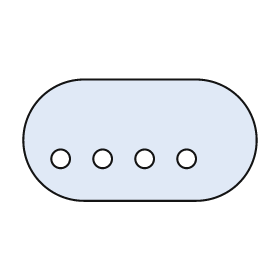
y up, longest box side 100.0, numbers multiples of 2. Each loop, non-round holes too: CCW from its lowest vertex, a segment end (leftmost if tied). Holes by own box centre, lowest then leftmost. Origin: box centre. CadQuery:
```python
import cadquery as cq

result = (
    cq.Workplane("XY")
    .moveTo(-24.0, -26.0)
    .lineTo(24.0, -26.0)
    .threePointArc((50.0, 0.0), (24.0, 26.0))
    .lineTo(-24.0, 26.0)
    .threePointArc((-50.0, 0.0), (-24.0, -26.0))
    .close()
    .moveTo(-34.0, -8.0)
    .circle(4.0)
    .moveTo(-16.0, -8.0)
    .circle(4.0)
    .moveTo(2.0, -8.0)
    .circle(4.0)
    .moveTo(20.0, -8.0)
    .circle(4.0)
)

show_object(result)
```